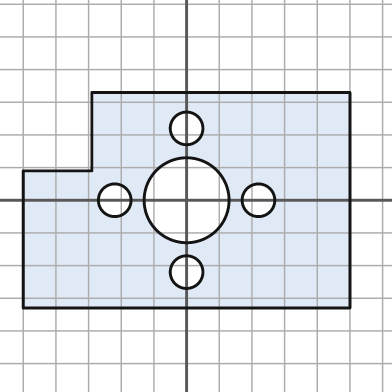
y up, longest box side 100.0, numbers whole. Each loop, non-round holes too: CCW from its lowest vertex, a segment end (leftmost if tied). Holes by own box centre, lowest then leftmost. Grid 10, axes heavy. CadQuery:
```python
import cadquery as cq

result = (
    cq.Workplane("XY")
    .moveTo(-50.0, -33.0)
    .lineTo(50.0, -33.0)
    .lineTo(50.0, 33.0)
    .lineTo(-29.0, 33.0)
    .lineTo(-29.0, 9.0)
    .lineTo(-50.0, 9.0)
    .close()
    .moveTo(0.0, -22.0)
    .circle(5.0)
    .moveTo(-22.0, 0.0)
    .circle(5.0)
    .moveTo(0.0, 0.0)
    .circle(13.0)
    .moveTo(22.0, 0.0)
    .circle(5.0)
    .moveTo(0.0, 22.0)
    .circle(5.0)
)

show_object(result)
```